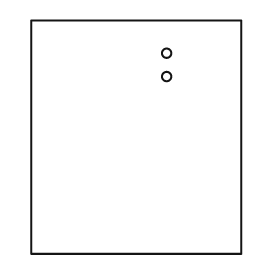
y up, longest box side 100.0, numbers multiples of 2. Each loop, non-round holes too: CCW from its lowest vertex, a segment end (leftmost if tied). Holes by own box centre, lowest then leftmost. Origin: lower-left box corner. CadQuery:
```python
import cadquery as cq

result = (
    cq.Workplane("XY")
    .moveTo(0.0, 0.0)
    .lineTo(90.0, 0.0)
    .lineTo(90.0, 100.0)
    .lineTo(0.0, 100.0)
    .close()
    .moveTo(58.0, 76.0)
    .circle(2.0)
    .moveTo(58.0, 86.0)
    .circle(2.0)
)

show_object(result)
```